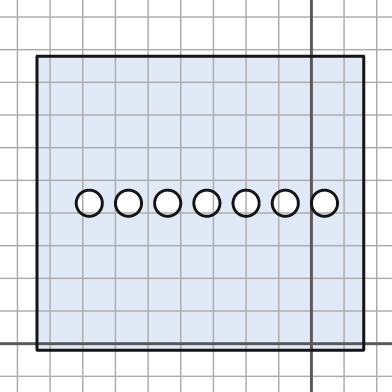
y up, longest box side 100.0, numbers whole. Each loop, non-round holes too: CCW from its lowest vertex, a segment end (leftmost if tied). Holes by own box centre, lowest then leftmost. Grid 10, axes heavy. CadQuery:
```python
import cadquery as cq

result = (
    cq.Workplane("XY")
    .moveTo(-84.0, -2.0)
    .lineTo(16.0, -2.0)
    .lineTo(16.0, 88.0)
    .lineTo(-84.0, 88.0)
    .close()
    .moveTo(-68.0, 43.0)
    .circle(4.0)
    .moveTo(-56.0, 43.0)
    .circle(4.0)
    .moveTo(-44.0, 43.0)
    .circle(4.0)
    .moveTo(-32.0, 43.0)
    .circle(4.0)
    .moveTo(-20.0, 43.0)
    .circle(4.0)
    .moveTo(-8.0, 43.0)
    .circle(4.0)
    .moveTo(4.0, 43.0)
    .circle(4.0)
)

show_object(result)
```